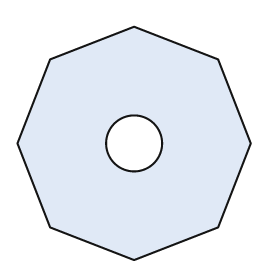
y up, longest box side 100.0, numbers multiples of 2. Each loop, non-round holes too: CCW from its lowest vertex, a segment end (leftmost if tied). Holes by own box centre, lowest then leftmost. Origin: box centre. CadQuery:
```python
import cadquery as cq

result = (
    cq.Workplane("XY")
    .moveTo(0.0, -50.0)
    .lineTo(36.0, -36.0)
    .lineTo(50.0, 0.0)
    .lineTo(36.0, 36.0)
    .lineTo(0.0, 50.0)
    .lineTo(-36.0, 36.0)
    .lineTo(-50.0, 0.0)
    .lineTo(-36.0, -36.0)
    .close()
    .moveTo(0.0, 0.0)
    .circle(12.0)
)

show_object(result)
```